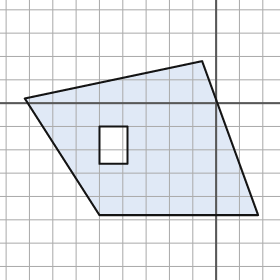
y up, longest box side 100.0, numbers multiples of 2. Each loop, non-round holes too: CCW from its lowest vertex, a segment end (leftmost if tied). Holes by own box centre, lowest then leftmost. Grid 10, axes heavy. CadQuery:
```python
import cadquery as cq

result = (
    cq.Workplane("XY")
    .moveTo(-50.0, -48.0)
    .lineTo(18.0, -48.0)
    .lineTo(-6.0, 18.0)
    .lineTo(-82.0, 2.0)
    .close()
    .moveTo(-50.0, -26.0)
    .lineTo(-38.0, -26.0)
    .lineTo(-38.0, -10.0)
    .lineTo(-50.0, -10.0)
    .close()
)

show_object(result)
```